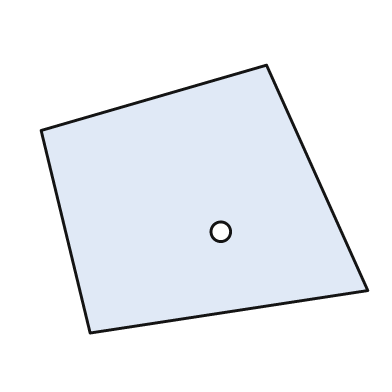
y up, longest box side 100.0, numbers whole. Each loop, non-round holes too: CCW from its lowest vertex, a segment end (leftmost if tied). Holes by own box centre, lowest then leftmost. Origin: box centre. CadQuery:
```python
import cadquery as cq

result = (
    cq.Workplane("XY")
    .moveTo(-35.0, -41.0)
    .lineTo(50.0, -28.0)
    .lineTo(19.0, 41.0)
    .lineTo(-50.0, 21.0)
    .close()
    .moveTo(5.0, -10.0)
    .circle(3.0)
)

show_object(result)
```